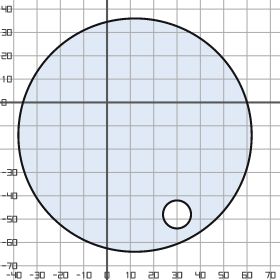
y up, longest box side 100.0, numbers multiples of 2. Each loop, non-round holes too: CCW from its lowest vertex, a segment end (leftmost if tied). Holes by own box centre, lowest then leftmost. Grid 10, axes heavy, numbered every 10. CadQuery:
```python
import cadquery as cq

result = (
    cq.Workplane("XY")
    .moveTo(12.0, -14.0)
    .circle(50.0)
    .moveTo(30.0, -48.0)
    .circle(6.0)
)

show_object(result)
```